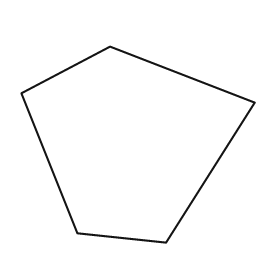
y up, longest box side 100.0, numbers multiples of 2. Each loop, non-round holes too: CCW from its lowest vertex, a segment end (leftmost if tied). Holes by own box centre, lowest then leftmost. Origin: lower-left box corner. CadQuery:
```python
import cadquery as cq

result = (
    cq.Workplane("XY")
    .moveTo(62.0, 0.0)
    .lineTo(100.0, 60.0)
    .lineTo(38.0, 84.0)
    .lineTo(0.0, 64.0)
    .lineTo(24.0, 4.0)
    .close()
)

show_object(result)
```